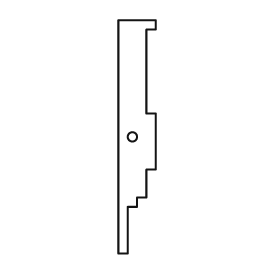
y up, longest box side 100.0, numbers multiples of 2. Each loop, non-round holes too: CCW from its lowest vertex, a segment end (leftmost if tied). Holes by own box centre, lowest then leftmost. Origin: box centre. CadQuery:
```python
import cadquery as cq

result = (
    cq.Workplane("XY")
    .moveTo(-8.0, -50.0)
    .lineTo(-4.0, -50.0)
    .lineTo(-4.0, -30.0)
    .lineTo(0.0, -30.0)
    .lineTo(0.0, -26.0)
    .lineTo(4.0, -26.0)
    .lineTo(4.0, -14.0)
    .lineTo(8.0, -14.0)
    .lineTo(8.0, 10.0)
    .lineTo(4.0, 10.0)
    .lineTo(4.0, 46.0)
    .lineTo(8.0, 46.0)
    .lineTo(8.0, 50.0)
    .lineTo(-8.0, 50.0)
    .close()
    .moveTo(-2.0, 0.0)
    .circle(2.0)
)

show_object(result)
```